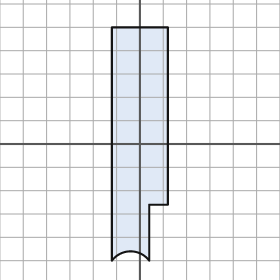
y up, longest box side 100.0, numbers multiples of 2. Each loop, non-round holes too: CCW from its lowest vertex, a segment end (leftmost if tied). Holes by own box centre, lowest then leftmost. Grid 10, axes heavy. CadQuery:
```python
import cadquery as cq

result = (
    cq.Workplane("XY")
    .moveTo(-12.0, -50.0)
    .threePointArc((-4.0, -46.0), (4.0, -50.0))
    .lineTo(4.0, -26.0)
    .lineTo(12.0, -26.0)
    .lineTo(12.0, 50.0)
    .lineTo(-12.0, 50.0)
    .close()
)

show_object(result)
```